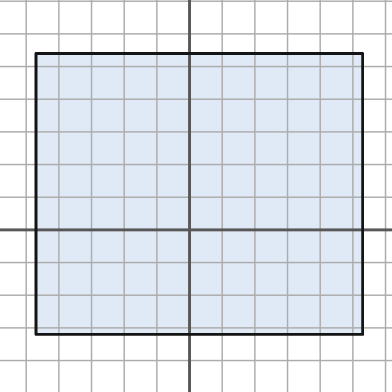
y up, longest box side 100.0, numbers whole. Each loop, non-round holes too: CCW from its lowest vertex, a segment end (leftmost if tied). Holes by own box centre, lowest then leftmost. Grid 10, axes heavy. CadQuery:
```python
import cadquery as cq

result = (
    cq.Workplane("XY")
    .moveTo(-47.0, -32.0)
    .lineTo(53.0, -32.0)
    .lineTo(53.0, 54.0)
    .lineTo(-47.0, 54.0)
    .close()
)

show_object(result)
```